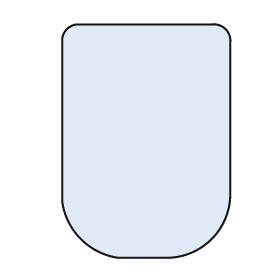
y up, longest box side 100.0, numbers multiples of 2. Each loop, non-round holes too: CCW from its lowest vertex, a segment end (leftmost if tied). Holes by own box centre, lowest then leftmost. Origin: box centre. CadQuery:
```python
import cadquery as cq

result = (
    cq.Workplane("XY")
    .moveTo(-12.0, -50.0)
    .lineTo(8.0, -50.0)
    .threePointArc((28.0, -42.0), (36.0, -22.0))
    .lineTo(36.0, 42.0)
    .threePointArc((34.0, 48.0), (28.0, 50.0))
    .lineTo(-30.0, 50.0)
    .threePointArc((-34.0, 48.0), (-36.0, 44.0))
    .lineTo(-36.0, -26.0)
    .threePointArc((-28.0, -42.0), (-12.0, -50.0))
    .close()
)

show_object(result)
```